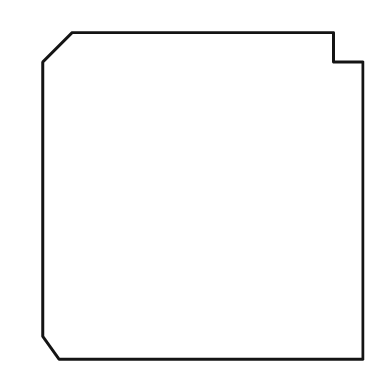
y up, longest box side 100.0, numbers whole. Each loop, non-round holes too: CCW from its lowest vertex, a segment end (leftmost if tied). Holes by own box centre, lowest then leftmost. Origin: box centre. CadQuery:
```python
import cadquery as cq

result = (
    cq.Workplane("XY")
    .moveTo(-44.0, -50.0)
    .lineTo(49.0, -50.0)
    .lineTo(49.0, 41.0)
    .lineTo(40.0, 41.0)
    .lineTo(40.0, 50.0)
    .lineTo(-40.0, 50.0)
    .lineTo(-49.0, 41.0)
    .lineTo(-49.0, -43.0)
    .close()
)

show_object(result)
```